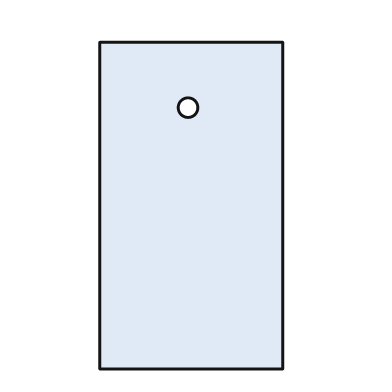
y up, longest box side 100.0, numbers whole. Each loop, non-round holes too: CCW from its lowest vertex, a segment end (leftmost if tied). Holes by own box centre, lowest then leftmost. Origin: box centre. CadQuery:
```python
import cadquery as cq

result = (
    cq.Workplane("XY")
    .moveTo(-28.0, -50.0)
    .lineTo(28.0, -50.0)
    .lineTo(28.0, 50.0)
    .lineTo(-28.0, 50.0)
    .close()
    .moveTo(-1.0, 30.0)
    .circle(3.0)
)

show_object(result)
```